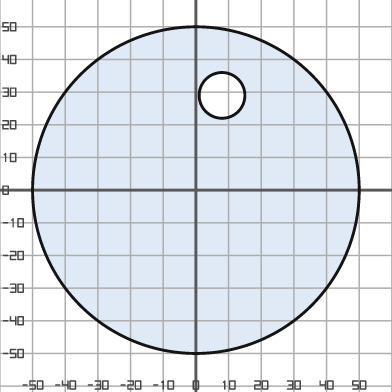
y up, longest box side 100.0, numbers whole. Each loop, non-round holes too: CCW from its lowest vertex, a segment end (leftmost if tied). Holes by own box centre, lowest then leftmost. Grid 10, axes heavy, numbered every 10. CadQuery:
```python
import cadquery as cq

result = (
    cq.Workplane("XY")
    .moveTo(0.0, 0.0)
    .circle(50.0)
    .moveTo(8.0, 29.0)
    .circle(7.0)
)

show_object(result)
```